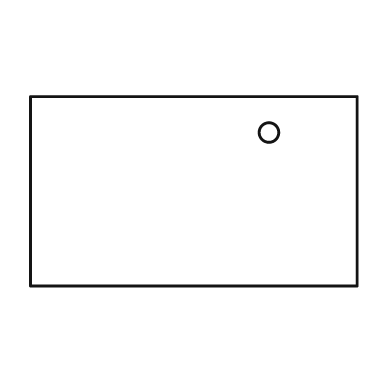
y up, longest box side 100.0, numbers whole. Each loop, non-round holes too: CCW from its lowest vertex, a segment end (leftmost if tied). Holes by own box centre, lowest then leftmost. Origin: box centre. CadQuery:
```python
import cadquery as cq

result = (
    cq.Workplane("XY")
    .moveTo(-50.0, -29.0)
    .lineTo(50.0, -29.0)
    .lineTo(50.0, 29.0)
    .lineTo(-50.0, 29.0)
    .close()
    .moveTo(23.0, 18.0)
    .circle(3.0)
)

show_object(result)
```